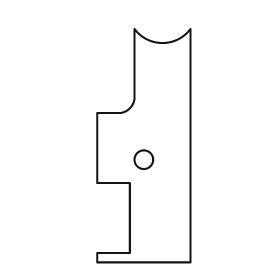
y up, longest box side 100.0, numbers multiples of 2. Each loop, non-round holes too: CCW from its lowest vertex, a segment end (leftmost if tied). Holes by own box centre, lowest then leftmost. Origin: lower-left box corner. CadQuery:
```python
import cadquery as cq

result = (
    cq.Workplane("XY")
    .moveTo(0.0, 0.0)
    .lineTo(40.0, 0.0)
    .lineTo(40.0, 100.0)
    .threePointArc((28.0, 94.0), (16.0, 100.0))
    .lineTo(16.0, 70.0)
    .threePointArc((14.0, 66.0), (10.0, 64.0))
    .lineTo(0.0, 64.0)
    .lineTo(0.0, 34.0)
    .lineTo(14.0, 34.0)
    .lineTo(14.0, 4.0)
    .lineTo(0.0, 4.0)
    .close()
    .moveTo(20.0, 44.0)
    .circle(4.0)
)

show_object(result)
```